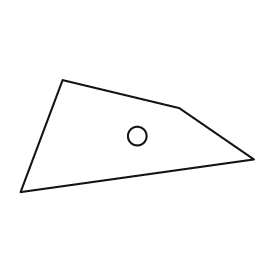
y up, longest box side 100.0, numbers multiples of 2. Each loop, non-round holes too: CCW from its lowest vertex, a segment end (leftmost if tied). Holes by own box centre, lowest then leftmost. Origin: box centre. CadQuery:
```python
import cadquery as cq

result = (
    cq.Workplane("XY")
    .moveTo(-50.0, -24.0)
    .lineTo(50.0, -10.0)
    .lineTo(18.0, 12.0)
    .lineTo(-32.0, 24.0)
    .close()
    .moveTo(0.0, 0.0)
    .circle(4.0)
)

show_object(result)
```